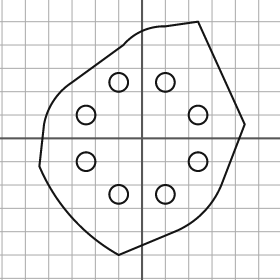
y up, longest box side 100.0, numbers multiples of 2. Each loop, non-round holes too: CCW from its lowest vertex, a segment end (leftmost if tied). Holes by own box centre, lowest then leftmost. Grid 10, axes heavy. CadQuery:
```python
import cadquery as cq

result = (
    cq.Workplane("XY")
    .moveTo(-10.0, -50.0)
    .lineTo(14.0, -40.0)
    .threePointArc((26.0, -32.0), (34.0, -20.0))
    .lineTo(44.0, 6.0)
    .lineTo(24.0, 50.0)
    .lineTo(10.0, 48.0)
    .threePointArc((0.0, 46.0), (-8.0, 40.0))
    .lineTo(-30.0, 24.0)
    .threePointArc((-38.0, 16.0), (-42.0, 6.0))
    .lineTo(-44.0, -12.0)
    .threePointArc((-30.0, -34.0), (-10.0, -50.0))
    .close()
    .moveTo(-10.0, -24.0)
    .circle(4.0)
    .moveTo(10.0, -24.0)
    .circle(4.0)
    .moveTo(-24.0, -10.0)
    .circle(4.0)
    .moveTo(24.0, -10.0)
    .circle(4.0)
    .moveTo(-24.0, 10.0)
    .circle(4.0)
    .moveTo(24.0, 10.0)
    .circle(4.0)
    .moveTo(-10.0, 24.0)
    .circle(4.0)
    .moveTo(10.0, 24.0)
    .circle(4.0)
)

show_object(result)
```